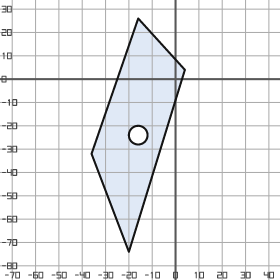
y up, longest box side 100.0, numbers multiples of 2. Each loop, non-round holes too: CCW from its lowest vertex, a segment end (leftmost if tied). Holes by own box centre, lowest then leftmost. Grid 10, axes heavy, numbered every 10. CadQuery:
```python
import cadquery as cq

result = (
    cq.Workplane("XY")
    .moveTo(-20.0, -74.0)
    .lineTo(4.0, 4.0)
    .lineTo(-16.0, 26.0)
    .lineTo(-36.0, -32.0)
    .close()
    .moveTo(-16.0, -24.0)
    .circle(4.0)
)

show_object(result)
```